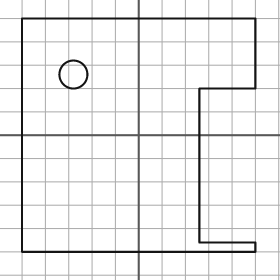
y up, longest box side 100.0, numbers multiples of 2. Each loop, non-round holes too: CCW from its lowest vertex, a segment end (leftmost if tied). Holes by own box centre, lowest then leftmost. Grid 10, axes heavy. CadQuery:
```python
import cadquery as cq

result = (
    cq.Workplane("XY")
    .moveTo(-50.0, -50.0)
    .lineTo(50.0, -50.0)
    .lineTo(50.0, -46.0)
    .lineTo(26.0, -46.0)
    .lineTo(26.0, 20.0)
    .lineTo(50.0, 20.0)
    .lineTo(50.0, 50.0)
    .lineTo(-50.0, 50.0)
    .close()
    .moveTo(-28.0, 26.0)
    .circle(6.0)
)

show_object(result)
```